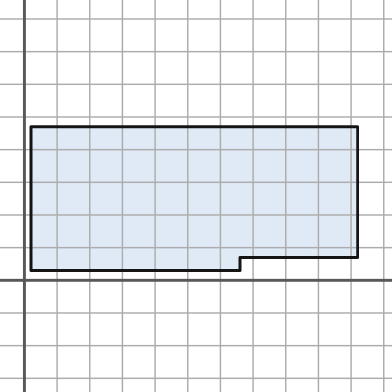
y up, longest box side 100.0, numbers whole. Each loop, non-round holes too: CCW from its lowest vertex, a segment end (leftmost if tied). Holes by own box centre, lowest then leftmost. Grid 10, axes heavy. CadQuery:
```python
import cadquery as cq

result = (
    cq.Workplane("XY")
    .moveTo(2.0, 3.0)
    .lineTo(66.0, 3.0)
    .lineTo(66.0, 7.0)
    .lineTo(102.0, 7.0)
    .lineTo(102.0, 47.0)
    .lineTo(2.0, 47.0)
    .close()
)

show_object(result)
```